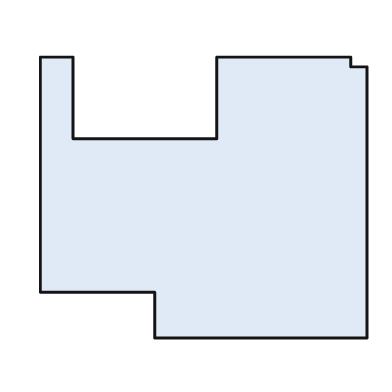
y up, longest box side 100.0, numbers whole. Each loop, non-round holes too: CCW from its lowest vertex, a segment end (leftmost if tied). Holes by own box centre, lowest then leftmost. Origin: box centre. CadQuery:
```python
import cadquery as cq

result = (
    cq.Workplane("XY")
    .moveTo(-15.0, -43.0)
    .lineTo(50.0, -43.0)
    .lineTo(50.0, 40.0)
    .lineTo(45.0, 40.0)
    .lineTo(45.0, 43.0)
    .lineTo(4.0, 43.0)
    .lineTo(4.0, 18.0)
    .lineTo(-40.0, 18.0)
    .lineTo(-40.0, 43.0)
    .lineTo(-50.0, 43.0)
    .lineTo(-50.0, -29.0)
    .lineTo(-15.0, -29.0)
    .close()
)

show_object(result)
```